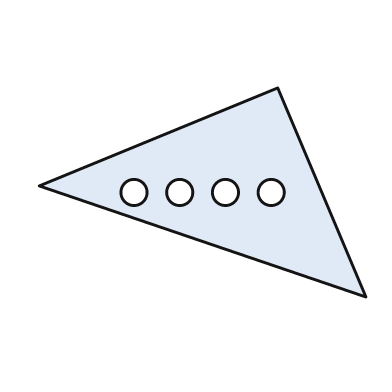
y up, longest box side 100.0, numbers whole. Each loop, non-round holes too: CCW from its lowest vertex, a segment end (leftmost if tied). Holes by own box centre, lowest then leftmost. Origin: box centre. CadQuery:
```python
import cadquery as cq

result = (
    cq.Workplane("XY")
    .moveTo(50.0, -32.0)
    .lineTo(23.0, 32.0)
    .lineTo(-50.0, 2.0)
    .close()
    .moveTo(-21.0, 0.0)
    .circle(4.0)
    .moveTo(-7.0, 0.0)
    .circle(4.0)
    .moveTo(7.0, 0.0)
    .circle(4.0)
    .moveTo(21.0, 0.0)
    .circle(4.0)
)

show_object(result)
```